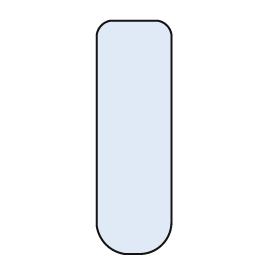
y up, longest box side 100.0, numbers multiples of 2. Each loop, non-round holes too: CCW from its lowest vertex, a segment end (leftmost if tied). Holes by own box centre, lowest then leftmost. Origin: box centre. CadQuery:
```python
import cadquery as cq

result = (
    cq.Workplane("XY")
    .moveTo(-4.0, -50.0)
    .lineTo(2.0, -50.0)
    .threePointArc((12.0, -46.0), (16.0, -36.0))
    .lineTo(16.0, 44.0)
    .threePointArc((14.0, 48.0), (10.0, 50.0))
    .lineTo(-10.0, 50.0)
    .threePointArc((-14.0, 48.0), (-16.0, 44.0))
    .lineTo(-16.0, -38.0)
    .threePointArc((-12.0, -46.0), (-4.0, -50.0))
    .close()
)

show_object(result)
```